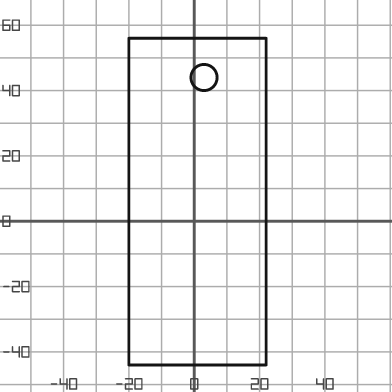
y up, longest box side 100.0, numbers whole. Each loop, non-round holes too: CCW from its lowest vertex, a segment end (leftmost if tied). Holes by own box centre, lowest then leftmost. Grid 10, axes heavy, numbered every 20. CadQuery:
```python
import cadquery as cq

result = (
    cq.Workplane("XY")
    .moveTo(-20.0, -44.0)
    .lineTo(22.0, -44.0)
    .lineTo(22.0, 56.0)
    .lineTo(-20.0, 56.0)
    .close()
    .moveTo(3.0, 44.0)
    .circle(4.0)
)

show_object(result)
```